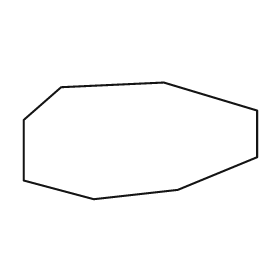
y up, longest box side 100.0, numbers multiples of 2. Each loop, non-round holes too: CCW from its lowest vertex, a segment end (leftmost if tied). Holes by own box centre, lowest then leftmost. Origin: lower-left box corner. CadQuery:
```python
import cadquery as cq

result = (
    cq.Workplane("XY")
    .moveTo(30.0, 0.0)
    .lineTo(66.0, 4.0)
    .lineTo(100.0, 18.0)
    .lineTo(100.0, 38.0)
    .lineTo(60.0, 50.0)
    .lineTo(16.0, 48.0)
    .lineTo(0.0, 34.0)
    .lineTo(0.0, 8.0)
    .close()
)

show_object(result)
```